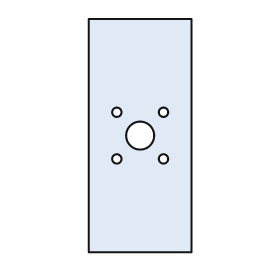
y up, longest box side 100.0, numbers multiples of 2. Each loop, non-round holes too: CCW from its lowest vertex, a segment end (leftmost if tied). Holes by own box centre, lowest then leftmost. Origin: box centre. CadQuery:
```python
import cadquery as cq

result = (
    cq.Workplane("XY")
    .moveTo(-22.0, -50.0)
    .lineTo(22.0, -50.0)
    .lineTo(22.0, 50.0)
    .lineTo(-22.0, 50.0)
    .close()
    .moveTo(-10.0, -10.0)
    .circle(2.0)
    .moveTo(10.0, -10.0)
    .circle(2.0)
    .moveTo(0.0, 0.0)
    .circle(6.0)
    .moveTo(-10.0, 10.0)
    .circle(2.0)
    .moveTo(10.0, 10.0)
    .circle(2.0)
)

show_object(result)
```